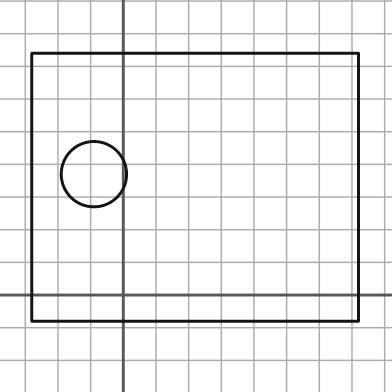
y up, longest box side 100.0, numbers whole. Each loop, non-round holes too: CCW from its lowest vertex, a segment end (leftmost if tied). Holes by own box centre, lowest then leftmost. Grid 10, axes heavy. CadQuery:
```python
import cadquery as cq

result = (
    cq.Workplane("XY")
    .moveTo(-28.0, -8.0)
    .lineTo(72.0, -8.0)
    .lineTo(72.0, 74.0)
    .lineTo(-28.0, 74.0)
    .close()
    .moveTo(-9.0, 37.0)
    .circle(10.0)
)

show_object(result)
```